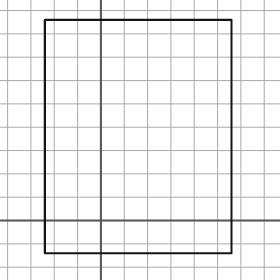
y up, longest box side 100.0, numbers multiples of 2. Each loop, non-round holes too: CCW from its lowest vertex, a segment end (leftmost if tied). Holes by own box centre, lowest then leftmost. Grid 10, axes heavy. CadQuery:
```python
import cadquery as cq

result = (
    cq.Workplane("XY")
    .moveTo(-24.0, -14.0)
    .lineTo(56.0, -14.0)
    .lineTo(56.0, 86.0)
    .lineTo(-24.0, 86.0)
    .close()
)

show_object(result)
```